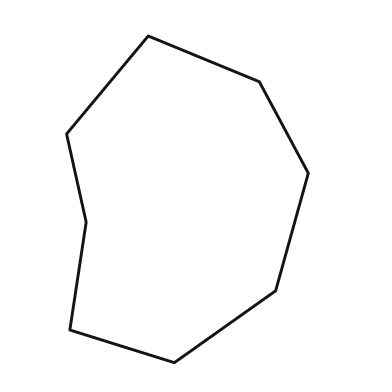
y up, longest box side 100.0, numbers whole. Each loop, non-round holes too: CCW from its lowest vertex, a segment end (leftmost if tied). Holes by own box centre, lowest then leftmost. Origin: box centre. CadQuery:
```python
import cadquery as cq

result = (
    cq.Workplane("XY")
    .moveTo(-4.0, -50.0)
    .lineTo(27.0, -28.0)
    .lineTo(37.0, 8.0)
    .lineTo(22.0, 36.0)
    .lineTo(-12.0, 50.0)
    .lineTo(-37.0, 20.0)
    .lineTo(-31.0, -7.0)
    .lineTo(-36.0, -40.0)
    .close()
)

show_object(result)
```